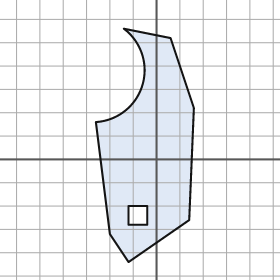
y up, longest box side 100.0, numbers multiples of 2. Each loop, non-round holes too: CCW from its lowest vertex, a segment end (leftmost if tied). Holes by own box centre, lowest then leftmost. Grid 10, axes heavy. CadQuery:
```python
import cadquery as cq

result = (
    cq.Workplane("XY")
    .moveTo(-12.0, -44.0)
    .lineTo(14.0, -26.0)
    .lineTo(16.0, 22.0)
    .lineTo(6.0, 52.0)
    .lineTo(-14.0, 56.0)
    .threePointArc((-6.0, 32.0), (-26.0, 16.0))
    .lineTo(-20.0, -32.0)
    .close()
    .moveTo(-12.0, -28.0)
    .lineTo(-4.0, -28.0)
    .lineTo(-4.0, -20.0)
    .lineTo(-12.0, -20.0)
    .close()
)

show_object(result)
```